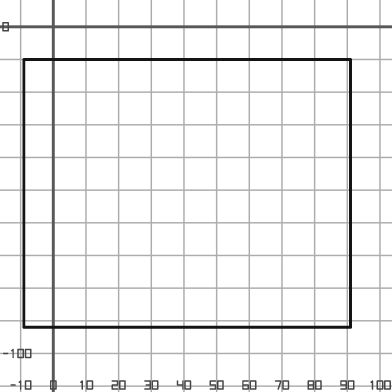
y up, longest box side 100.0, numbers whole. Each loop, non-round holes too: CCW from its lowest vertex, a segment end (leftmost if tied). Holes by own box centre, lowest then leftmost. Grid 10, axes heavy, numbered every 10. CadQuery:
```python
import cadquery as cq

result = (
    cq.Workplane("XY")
    .moveTo(-9.0, -92.0)
    .lineTo(91.0, -92.0)
    .lineTo(91.0, -10.0)
    .lineTo(-9.0, -10.0)
    .close()
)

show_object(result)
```